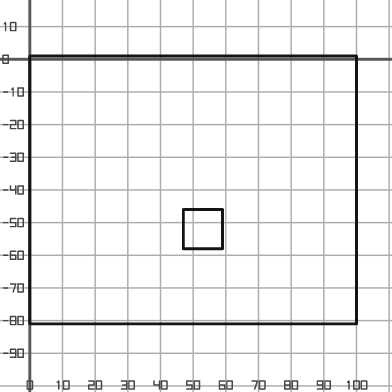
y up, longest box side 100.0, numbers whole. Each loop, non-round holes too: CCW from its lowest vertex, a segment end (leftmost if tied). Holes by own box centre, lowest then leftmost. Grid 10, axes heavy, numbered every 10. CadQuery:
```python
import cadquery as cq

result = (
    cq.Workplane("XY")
    .moveTo(0.0, -81.0)
    .lineTo(100.0, -81.0)
    .lineTo(100.0, 1.0)
    .lineTo(0.0, 1.0)
    .close()
    .moveTo(47.0, -58.0)
    .lineTo(59.0, -58.0)
    .lineTo(59.0, -46.0)
    .lineTo(47.0, -46.0)
    .close()
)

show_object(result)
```